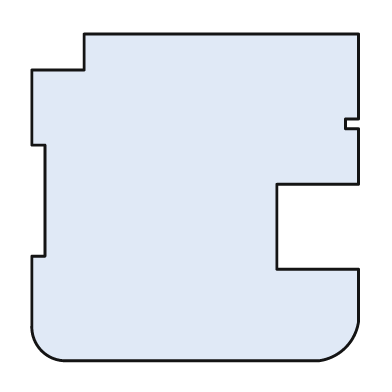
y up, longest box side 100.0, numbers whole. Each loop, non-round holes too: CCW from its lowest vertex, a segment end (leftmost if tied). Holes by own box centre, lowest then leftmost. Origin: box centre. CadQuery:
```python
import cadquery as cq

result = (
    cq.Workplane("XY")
    .moveTo(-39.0, -50.0)
    .lineTo(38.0, -50.0)
    .threePointArc((46.0, -46.0), (50.0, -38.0))
    .lineTo(50.0, -22.0)
    .lineTo(25.0, -22.0)
    .lineTo(25.0, 4.0)
    .lineTo(50.0, 4.0)
    .lineTo(50.0, 21.0)
    .lineTo(46.0, 21.0)
    .lineTo(46.0, 24.0)
    .lineTo(50.0, 24.0)
    .lineTo(50.0, 50.0)
    .lineTo(-34.0, 50.0)
    .lineTo(-34.0, 39.0)
    .lineTo(-50.0, 39.0)
    .lineTo(-50.0, 16.0)
    .lineTo(-46.0, 16.0)
    .lineTo(-46.0, -18.0)
    .lineTo(-50.0, -18.0)
    .lineTo(-50.0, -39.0)
    .threePointArc((-47.0, -47.0), (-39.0, -50.0))
    .close()
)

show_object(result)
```